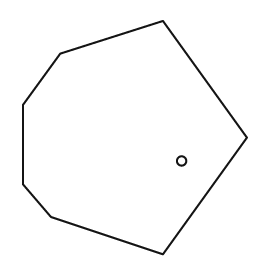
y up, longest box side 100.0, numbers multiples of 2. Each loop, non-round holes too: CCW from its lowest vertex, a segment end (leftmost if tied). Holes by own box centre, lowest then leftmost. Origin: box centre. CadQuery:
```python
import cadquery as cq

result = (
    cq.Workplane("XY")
    .moveTo(12.0, -50.0)
    .lineTo(48.0, 0.0)
    .lineTo(12.0, 50.0)
    .lineTo(-32.0, 36.0)
    .lineTo(-48.0, 14.0)
    .lineTo(-48.0, -20.0)
    .lineTo(-36.0, -34.0)
    .close()
    .moveTo(20.0, -10.0)
    .circle(2.0)
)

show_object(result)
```